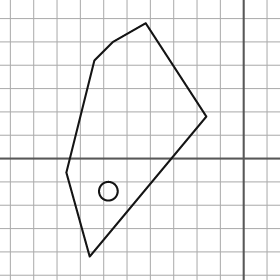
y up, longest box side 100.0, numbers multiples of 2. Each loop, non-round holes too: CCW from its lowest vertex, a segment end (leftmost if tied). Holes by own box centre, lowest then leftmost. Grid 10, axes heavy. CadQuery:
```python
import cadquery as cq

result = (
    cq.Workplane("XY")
    .moveTo(-66.0, -42.0)
    .lineTo(-16.0, 18.0)
    .lineTo(-42.0, 58.0)
    .lineTo(-56.0, 50.0)
    .lineTo(-64.0, 42.0)
    .lineTo(-76.0, -6.0)
    .close()
    .moveTo(-58.0, -14.0)
    .circle(4.0)
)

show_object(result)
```